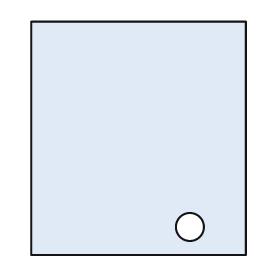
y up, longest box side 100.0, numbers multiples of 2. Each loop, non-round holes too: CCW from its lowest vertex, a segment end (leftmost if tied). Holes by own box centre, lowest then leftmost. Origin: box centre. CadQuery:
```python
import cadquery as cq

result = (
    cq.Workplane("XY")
    .moveTo(-46.0, -50.0)
    .lineTo(46.0, -50.0)
    .lineTo(46.0, 50.0)
    .lineTo(-46.0, 50.0)
    .close()
    .moveTo(22.0, -38.0)
    .circle(6.0)
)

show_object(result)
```